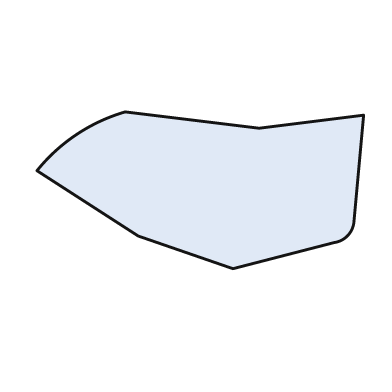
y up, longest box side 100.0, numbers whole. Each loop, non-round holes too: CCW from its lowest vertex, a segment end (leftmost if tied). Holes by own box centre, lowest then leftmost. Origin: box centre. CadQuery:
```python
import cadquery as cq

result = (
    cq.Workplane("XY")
    .moveTo(10.0, -24.0)
    .lineTo(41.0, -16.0)
    .threePointArc((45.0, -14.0), (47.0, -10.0))
    .lineTo(50.0, 23.0)
    .lineTo(18.0, 19.0)
    .lineTo(-23.0, 24.0)
    .threePointArc((-38.0, 17.0), (-50.0, 6.0))
    .lineTo(-19.0, -14.0)
    .close()
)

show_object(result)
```